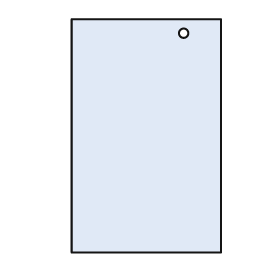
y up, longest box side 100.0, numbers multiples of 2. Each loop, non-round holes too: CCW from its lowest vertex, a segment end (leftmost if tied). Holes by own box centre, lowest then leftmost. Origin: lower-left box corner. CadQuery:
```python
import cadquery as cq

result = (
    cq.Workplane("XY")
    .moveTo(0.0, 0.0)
    .lineTo(64.0, 0.0)
    .lineTo(64.0, 100.0)
    .lineTo(0.0, 100.0)
    .close()
    .moveTo(48.0, 94.0)
    .circle(2.0)
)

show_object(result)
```